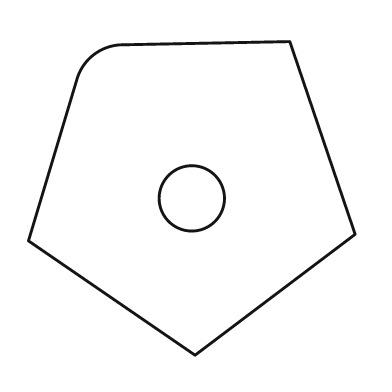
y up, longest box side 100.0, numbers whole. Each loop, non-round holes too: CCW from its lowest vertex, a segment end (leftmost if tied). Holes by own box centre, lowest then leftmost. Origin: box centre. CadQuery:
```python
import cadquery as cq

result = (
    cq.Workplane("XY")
    .moveTo(1.0, -48.0)
    .lineTo(50.0, -11.0)
    .lineTo(30.0, 48.0)
    .lineTo(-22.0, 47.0)
    .threePointArc((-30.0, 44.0), (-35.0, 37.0))
    .lineTo(-50.0, -13.0)
    .close()
    .moveTo(0.0, 0.0)
    .circle(10.0)
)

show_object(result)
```